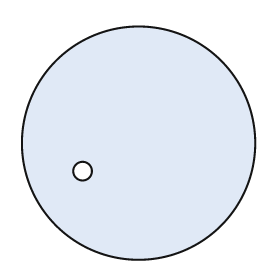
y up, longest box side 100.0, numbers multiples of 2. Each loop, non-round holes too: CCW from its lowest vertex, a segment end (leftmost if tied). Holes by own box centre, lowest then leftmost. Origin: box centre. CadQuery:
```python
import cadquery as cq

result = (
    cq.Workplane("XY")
    .moveTo(0.0, 0.0)
    .circle(50.0)
    .moveTo(-24.0, -12.0)
    .circle(4.0)
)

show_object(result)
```